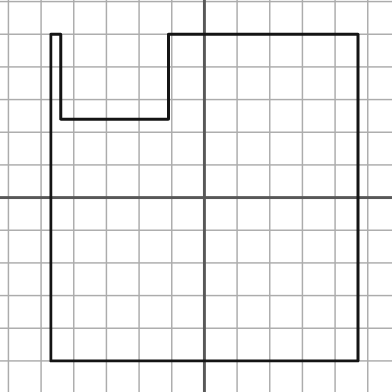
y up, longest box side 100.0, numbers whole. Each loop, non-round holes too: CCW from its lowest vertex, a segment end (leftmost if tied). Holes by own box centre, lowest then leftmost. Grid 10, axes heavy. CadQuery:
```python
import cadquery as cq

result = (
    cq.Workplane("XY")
    .moveTo(-47.0, -50.0)
    .lineTo(47.0, -50.0)
    .lineTo(47.0, 50.0)
    .lineTo(-11.0, 50.0)
    .lineTo(-11.0, 24.0)
    .lineTo(-44.0, 24.0)
    .lineTo(-44.0, 50.0)
    .lineTo(-47.0, 50.0)
    .close()
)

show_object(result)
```